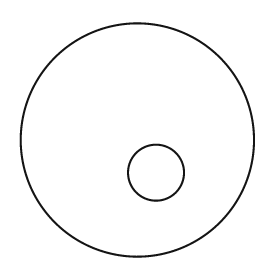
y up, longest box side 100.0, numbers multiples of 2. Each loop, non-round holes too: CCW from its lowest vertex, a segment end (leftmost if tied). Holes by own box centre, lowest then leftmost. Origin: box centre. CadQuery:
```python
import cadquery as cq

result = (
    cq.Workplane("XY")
    .moveTo(0.0, 0.0)
    .circle(50.0)
    .moveTo(8.0, -14.0)
    .circle(12.0)
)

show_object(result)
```